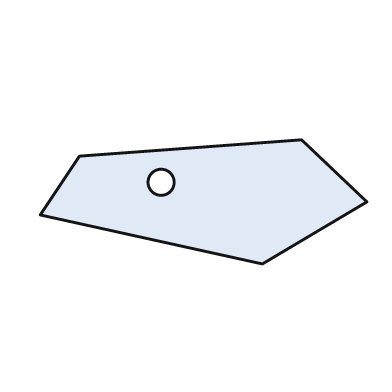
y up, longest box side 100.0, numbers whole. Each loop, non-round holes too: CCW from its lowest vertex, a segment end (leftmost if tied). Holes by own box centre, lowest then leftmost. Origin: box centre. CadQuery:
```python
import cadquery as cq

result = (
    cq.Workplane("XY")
    .moveTo(18.0, -19.0)
    .lineTo(50.0, 0.0)
    .lineTo(30.0, 19.0)
    .lineTo(-38.0, 14.0)
    .lineTo(-50.0, -4.0)
    .close()
    .moveTo(-13.0, 6.0)
    .circle(4.0)
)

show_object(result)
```